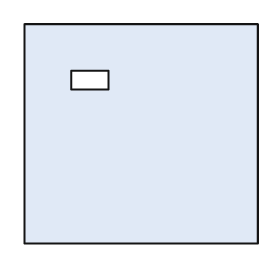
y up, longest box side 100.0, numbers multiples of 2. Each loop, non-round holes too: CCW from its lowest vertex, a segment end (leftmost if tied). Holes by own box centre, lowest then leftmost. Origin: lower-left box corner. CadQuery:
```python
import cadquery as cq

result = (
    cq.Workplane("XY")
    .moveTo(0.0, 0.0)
    .lineTo(100.0, 0.0)
    .lineTo(100.0, 94.0)
    .lineTo(0.0, 94.0)
    .close()
    .moveTo(20.0, 66.0)
    .lineTo(36.0, 66.0)
    .lineTo(36.0, 74.0)
    .lineTo(20.0, 74.0)
    .close()
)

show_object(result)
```